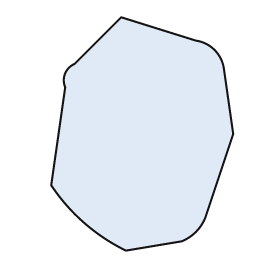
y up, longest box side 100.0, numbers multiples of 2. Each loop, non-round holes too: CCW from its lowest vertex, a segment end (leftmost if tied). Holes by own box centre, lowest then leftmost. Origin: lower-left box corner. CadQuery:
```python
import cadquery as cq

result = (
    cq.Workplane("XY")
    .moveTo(32.0, 0.0)
    .lineTo(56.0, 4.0)
    .threePointArc((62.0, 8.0), (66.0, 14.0))
    .lineTo(78.0, 50.0)
    .lineTo(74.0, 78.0)
    .threePointArc((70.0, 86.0), (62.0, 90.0))
    .lineTo(30.0, 100.0)
    .lineTo(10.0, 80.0)
    .threePointArc((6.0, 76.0), (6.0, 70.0))
    .lineTo(0.0, 28.0)
    .threePointArc((14.0, 12.0), (32.0, 0.0))
    .close()
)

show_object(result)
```